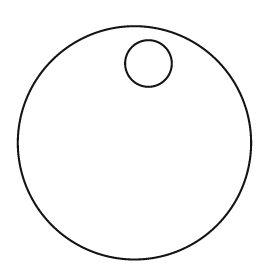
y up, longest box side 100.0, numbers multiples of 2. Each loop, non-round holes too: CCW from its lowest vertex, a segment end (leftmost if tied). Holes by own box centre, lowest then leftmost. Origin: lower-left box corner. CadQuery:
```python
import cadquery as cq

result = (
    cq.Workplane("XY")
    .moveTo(50.0, 50.0)
    .circle(50.0)
    .moveTo(56.0, 84.0)
    .circle(10.0)
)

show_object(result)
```